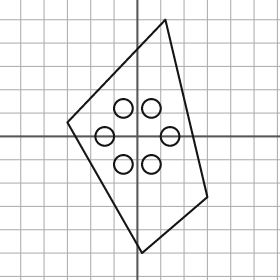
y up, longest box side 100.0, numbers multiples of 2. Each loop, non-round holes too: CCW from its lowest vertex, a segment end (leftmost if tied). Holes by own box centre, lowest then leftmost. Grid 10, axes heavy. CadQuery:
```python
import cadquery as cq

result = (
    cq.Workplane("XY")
    .moveTo(2.0, -50.0)
    .lineTo(30.0, -26.0)
    .lineTo(12.0, 50.0)
    .lineTo(-30.0, 6.0)
    .close()
    .moveTo(-6.0, -12.0)
    .circle(4.0)
    .moveTo(6.0, -12.0)
    .circle(4.0)
    .moveTo(-14.0, 0.0)
    .circle(4.0)
    .moveTo(14.0, 0.0)
    .circle(4.0)
    .moveTo(-6.0, 12.0)
    .circle(4.0)
    .moveTo(6.0, 12.0)
    .circle(4.0)
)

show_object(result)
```